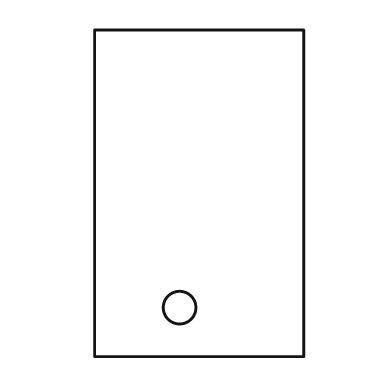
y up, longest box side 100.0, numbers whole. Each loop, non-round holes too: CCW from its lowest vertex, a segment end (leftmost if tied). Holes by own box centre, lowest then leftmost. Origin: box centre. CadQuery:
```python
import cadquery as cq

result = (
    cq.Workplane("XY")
    .moveTo(-32.0, -50.0)
    .lineTo(32.0, -50.0)
    .lineTo(32.0, 50.0)
    .lineTo(-32.0, 50.0)
    .close()
    .moveTo(-6.0, -35.0)
    .circle(5.0)
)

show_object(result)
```